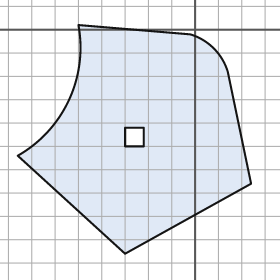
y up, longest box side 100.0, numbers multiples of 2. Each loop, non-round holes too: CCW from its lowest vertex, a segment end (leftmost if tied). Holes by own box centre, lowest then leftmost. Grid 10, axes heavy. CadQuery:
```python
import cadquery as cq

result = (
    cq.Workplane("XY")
    .moveTo(-30.0, -96.0)
    .lineTo(24.0, -66.0)
    .lineTo(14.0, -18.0)
    .threePointArc((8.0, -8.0), (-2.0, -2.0))
    .lineTo(-50.0, 2.0)
    .threePointArc((-54.0, -30.0), (-76.0, -54.0))
    .close()
    .moveTo(-30.0, -50.0)
    .lineTo(-22.0, -50.0)
    .lineTo(-22.0, -42.0)
    .lineTo(-30.0, -42.0)
    .close()
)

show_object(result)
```